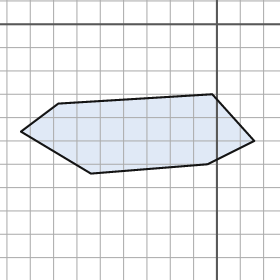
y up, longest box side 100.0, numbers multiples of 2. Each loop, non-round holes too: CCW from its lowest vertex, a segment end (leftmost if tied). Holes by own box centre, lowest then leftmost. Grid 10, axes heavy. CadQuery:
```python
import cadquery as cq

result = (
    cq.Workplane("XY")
    .moveTo(-54.0, -64.0)
    .lineTo(-4.0, -60.0)
    .lineTo(16.0, -50.0)
    .lineTo(-2.0, -30.0)
    .lineTo(-68.0, -34.0)
    .lineTo(-84.0, -46.0)
    .close()
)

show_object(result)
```